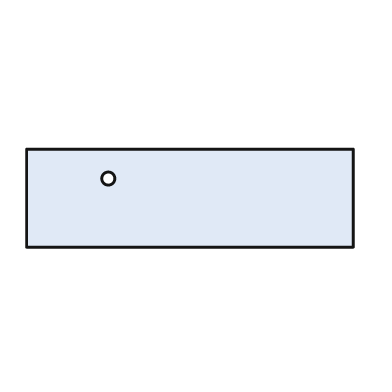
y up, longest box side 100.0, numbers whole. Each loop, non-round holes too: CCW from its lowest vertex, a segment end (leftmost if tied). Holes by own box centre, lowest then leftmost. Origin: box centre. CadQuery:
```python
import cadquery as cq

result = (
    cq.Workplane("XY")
    .moveTo(-50.0, -15.0)
    .lineTo(50.0, -15.0)
    .lineTo(50.0, 15.0)
    .lineTo(-50.0, 15.0)
    .close()
    .moveTo(-25.0, 6.0)
    .circle(2.0)
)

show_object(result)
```